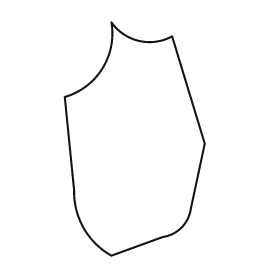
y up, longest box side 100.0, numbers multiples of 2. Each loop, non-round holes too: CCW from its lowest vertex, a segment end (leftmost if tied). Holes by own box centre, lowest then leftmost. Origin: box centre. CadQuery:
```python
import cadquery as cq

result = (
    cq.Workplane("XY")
    .moveTo(-10.0, -50.0)
    .lineTo(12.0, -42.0)
    .threePointArc((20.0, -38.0), (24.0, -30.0))
    .lineTo(30.0, -2.0)
    .lineTo(16.0, 44.0)
    .threePointArc((2.0, 42.0), (-10.0, 50.0))
    .threePointArc((-14.0, 30.0), (-30.0, 18.0))
    .lineTo(-26.0, -22.0)
    .threePointArc((-22.0, -38.0), (-10.0, -50.0))
    .close()
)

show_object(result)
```